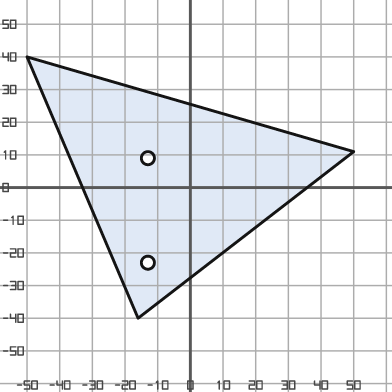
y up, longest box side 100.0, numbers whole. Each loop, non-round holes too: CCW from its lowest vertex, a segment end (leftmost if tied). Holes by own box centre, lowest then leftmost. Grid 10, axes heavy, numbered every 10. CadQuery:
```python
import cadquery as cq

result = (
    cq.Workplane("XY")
    .moveTo(-16.0, -40.0)
    .lineTo(50.0, 11.0)
    .lineTo(-50.0, 40.0)
    .close()
    .moveTo(-13.0, -23.0)
    .circle(2.0)
    .moveTo(-13.0, 9.0)
    .circle(2.0)
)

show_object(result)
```